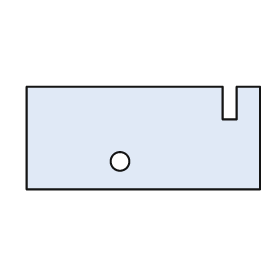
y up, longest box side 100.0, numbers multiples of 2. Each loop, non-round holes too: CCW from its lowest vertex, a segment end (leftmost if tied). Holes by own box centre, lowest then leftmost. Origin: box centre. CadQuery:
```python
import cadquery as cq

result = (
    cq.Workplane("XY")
    .moveTo(-50.0, -22.0)
    .lineTo(50.0, -22.0)
    .lineTo(50.0, 22.0)
    .lineTo(40.0, 22.0)
    .lineTo(40.0, 8.0)
    .lineTo(34.0, 8.0)
    .lineTo(34.0, 22.0)
    .lineTo(-50.0, 22.0)
    .close()
    .moveTo(-10.0, -10.0)
    .circle(4.0)
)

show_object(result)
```